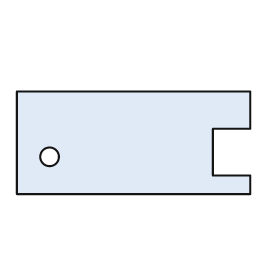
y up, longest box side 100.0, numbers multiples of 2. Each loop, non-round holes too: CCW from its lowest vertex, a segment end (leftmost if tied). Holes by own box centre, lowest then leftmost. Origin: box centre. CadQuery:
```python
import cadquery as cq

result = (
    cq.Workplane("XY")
    .moveTo(-50.0, -22.0)
    .lineTo(50.0, -22.0)
    .lineTo(50.0, -14.0)
    .lineTo(34.0, -14.0)
    .lineTo(34.0, 6.0)
    .lineTo(50.0, 6.0)
    .lineTo(50.0, 22.0)
    .lineTo(-50.0, 22.0)
    .close()
    .moveTo(-36.0, -6.0)
    .circle(4.0)
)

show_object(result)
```